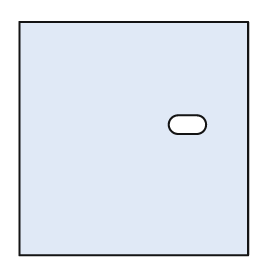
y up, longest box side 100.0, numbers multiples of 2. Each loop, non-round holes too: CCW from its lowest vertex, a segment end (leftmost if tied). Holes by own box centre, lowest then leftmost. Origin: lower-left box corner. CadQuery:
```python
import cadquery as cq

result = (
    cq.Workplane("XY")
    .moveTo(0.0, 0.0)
    .lineTo(98.0, 0.0)
    .lineTo(98.0, 100.0)
    .lineTo(0.0, 100.0)
    .close()
    .moveTo(68.0, 52.0)
    .lineTo(76.0, 52.0)
    .threePointArc((80.0, 56.0), (76.0, 60.0))
    .lineTo(68.0, 60.0)
    .threePointArc((64.0, 56.0), (68.0, 52.0))
    .close()
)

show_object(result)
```